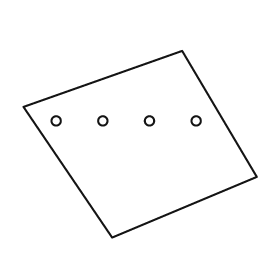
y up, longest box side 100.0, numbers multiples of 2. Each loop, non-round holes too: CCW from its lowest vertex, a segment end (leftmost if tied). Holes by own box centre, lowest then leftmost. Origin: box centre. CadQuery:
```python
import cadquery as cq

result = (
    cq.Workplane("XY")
    .moveTo(-12.0, -40.0)
    .lineTo(50.0, -14.0)
    .lineTo(18.0, 40.0)
    .lineTo(-50.0, 16.0)
    .close()
    .moveTo(-36.0, 10.0)
    .circle(2.0)
    .moveTo(-16.0, 10.0)
    .circle(2.0)
    .moveTo(4.0, 10.0)
    .circle(2.0)
    .moveTo(24.0, 10.0)
    .circle(2.0)
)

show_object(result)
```